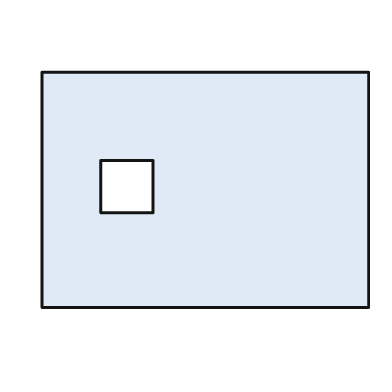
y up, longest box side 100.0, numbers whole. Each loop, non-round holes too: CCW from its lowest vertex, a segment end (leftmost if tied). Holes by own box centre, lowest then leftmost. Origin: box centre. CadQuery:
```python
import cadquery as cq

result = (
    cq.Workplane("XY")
    .moveTo(-50.0, -36.0)
    .lineTo(50.0, -36.0)
    .lineTo(50.0, 36.0)
    .lineTo(-50.0, 36.0)
    .close()
    .moveTo(-32.0, -7.0)
    .lineTo(-16.0, -7.0)
    .lineTo(-16.0, 9.0)
    .lineTo(-32.0, 9.0)
    .close()
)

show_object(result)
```